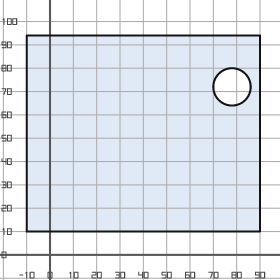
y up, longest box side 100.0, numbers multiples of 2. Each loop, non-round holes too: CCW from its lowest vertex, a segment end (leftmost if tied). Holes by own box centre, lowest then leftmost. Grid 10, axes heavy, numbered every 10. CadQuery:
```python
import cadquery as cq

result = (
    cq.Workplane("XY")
    .moveTo(-10.0, 10.0)
    .lineTo(90.0, 10.0)
    .lineTo(90.0, 94.0)
    .lineTo(-10.0, 94.0)
    .close()
    .moveTo(78.0, 72.0)
    .circle(8.0)
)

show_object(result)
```